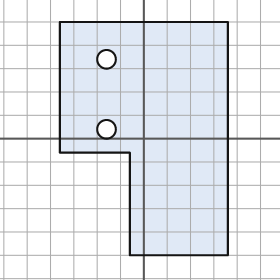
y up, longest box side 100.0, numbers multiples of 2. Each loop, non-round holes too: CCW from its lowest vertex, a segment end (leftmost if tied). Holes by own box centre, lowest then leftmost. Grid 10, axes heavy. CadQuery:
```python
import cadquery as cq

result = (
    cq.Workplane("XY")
    .moveTo(-6.0, -50.0)
    .lineTo(36.0, -50.0)
    .lineTo(36.0, 50.0)
    .lineTo(-36.0, 50.0)
    .lineTo(-36.0, -6.0)
    .lineTo(-6.0, -6.0)
    .close()
    .moveTo(-16.0, 4.0)
    .circle(4.0)
    .moveTo(-16.0, 34.0)
    .circle(4.0)
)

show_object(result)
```